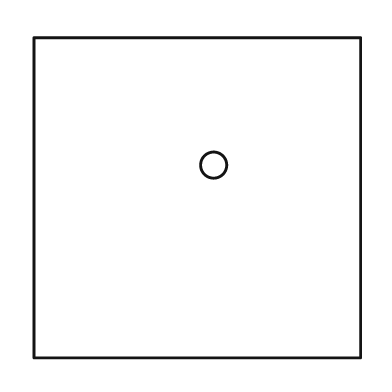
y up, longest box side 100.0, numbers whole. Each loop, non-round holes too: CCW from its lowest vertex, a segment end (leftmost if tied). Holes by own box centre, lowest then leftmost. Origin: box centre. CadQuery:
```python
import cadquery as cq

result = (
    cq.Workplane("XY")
    .moveTo(-50.0, -49.0)
    .lineTo(50.0, -49.0)
    .lineTo(50.0, 49.0)
    .lineTo(-50.0, 49.0)
    .close()
    .moveTo(5.0, 10.0)
    .circle(4.0)
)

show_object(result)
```